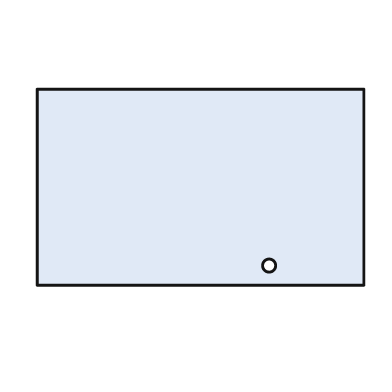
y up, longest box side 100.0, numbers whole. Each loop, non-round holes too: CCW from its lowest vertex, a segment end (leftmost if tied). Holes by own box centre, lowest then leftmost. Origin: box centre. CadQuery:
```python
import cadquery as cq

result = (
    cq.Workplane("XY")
    .moveTo(-50.0, -30.0)
    .lineTo(50.0, -30.0)
    .lineTo(50.0, 30.0)
    .lineTo(-50.0, 30.0)
    .close()
    .moveTo(21.0, -24.0)
    .circle(2.0)
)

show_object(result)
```